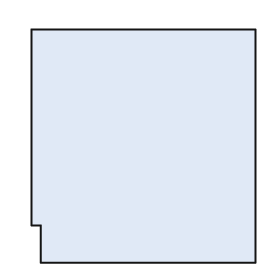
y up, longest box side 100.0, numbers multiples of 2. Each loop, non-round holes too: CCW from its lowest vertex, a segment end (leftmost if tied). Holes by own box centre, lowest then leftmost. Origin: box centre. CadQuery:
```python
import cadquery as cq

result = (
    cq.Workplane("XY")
    .moveTo(-44.0, -50.0)
    .lineTo(48.0, -50.0)
    .lineTo(48.0, 50.0)
    .lineTo(-48.0, 50.0)
    .lineTo(-48.0, -34.0)
    .lineTo(-44.0, -34.0)
    .close()
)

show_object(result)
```